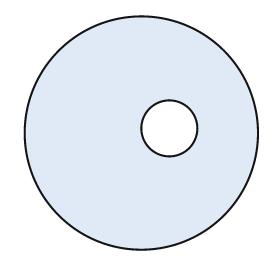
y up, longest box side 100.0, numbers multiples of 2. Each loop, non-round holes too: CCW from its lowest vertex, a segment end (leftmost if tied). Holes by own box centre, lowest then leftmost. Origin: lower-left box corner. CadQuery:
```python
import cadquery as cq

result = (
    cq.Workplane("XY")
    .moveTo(50.0, 50.0)
    .circle(50.0)
    .moveTo(62.0, 52.0)
    .circle(12.0)
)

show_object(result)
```